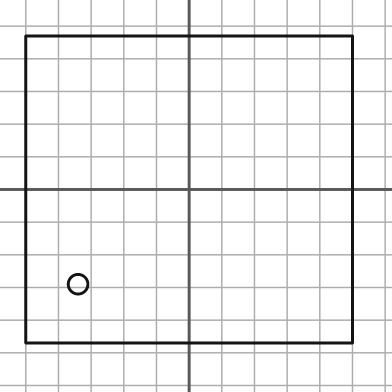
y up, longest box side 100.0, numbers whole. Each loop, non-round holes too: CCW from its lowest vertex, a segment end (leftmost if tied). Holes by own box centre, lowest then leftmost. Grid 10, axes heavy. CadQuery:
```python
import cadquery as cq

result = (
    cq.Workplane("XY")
    .moveTo(-50.0, -47.0)
    .lineTo(50.0, -47.0)
    .lineTo(50.0, 47.0)
    .lineTo(-50.0, 47.0)
    .close()
    .moveTo(-34.0, -29.0)
    .circle(3.0)
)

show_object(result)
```